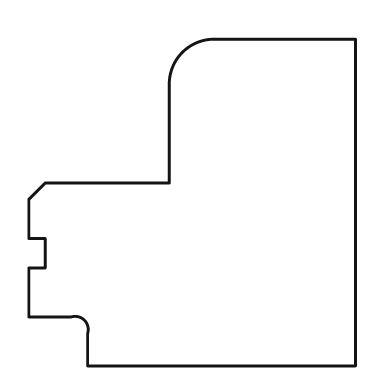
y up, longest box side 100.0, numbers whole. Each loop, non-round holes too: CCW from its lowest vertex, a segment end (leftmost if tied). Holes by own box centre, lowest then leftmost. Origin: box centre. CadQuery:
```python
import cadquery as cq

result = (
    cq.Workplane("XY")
    .moveTo(-32.0, -50.0)
    .lineTo(50.0, -50.0)
    .lineTo(50.0, 50.0)
    .lineTo(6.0, 50.0)
    .threePointArc((-3.0, 46.0), (-7.0, 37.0))
    .lineTo(-7.0, 6.0)
    .lineTo(-45.0, 6.0)
    .lineTo(-50.0, 1.0)
    .lineTo(-50.0, -11.0)
    .lineTo(-45.0, -11.0)
    .lineTo(-45.0, -20.0)
    .lineTo(-50.0, -20.0)
    .lineTo(-50.0, -35.0)
    .lineTo(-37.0, -35.0)
    .threePointArc((-33.0, -36.0), (-32.0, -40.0))
    .close()
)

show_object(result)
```